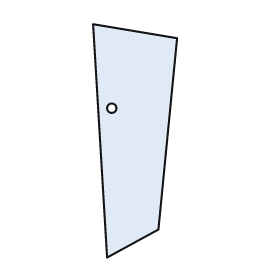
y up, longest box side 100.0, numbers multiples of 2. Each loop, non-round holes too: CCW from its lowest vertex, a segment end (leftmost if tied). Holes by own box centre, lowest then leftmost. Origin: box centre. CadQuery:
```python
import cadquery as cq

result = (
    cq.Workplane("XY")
    .moveTo(-12.0, -50.0)
    .lineTo(10.0, -38.0)
    .lineTo(18.0, 44.0)
    .lineTo(-18.0, 50.0)
    .close()
    .moveTo(-10.0, 14.0)
    .circle(2.0)
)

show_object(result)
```